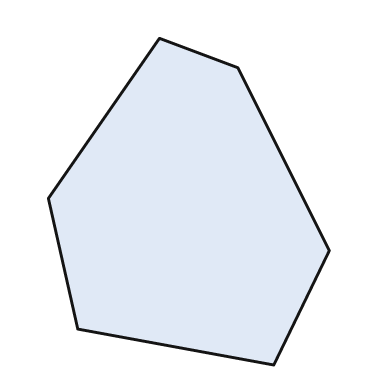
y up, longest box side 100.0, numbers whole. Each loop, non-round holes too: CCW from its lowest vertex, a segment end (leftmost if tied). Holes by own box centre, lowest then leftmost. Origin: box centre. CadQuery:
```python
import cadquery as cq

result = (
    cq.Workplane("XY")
    .moveTo(26.0, -50.0)
    .lineTo(43.0, -15.0)
    .lineTo(15.0, 41.0)
    .lineTo(-9.0, 50.0)
    .lineTo(-43.0, 1.0)
    .lineTo(-34.0, -39.0)
    .close()
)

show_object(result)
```